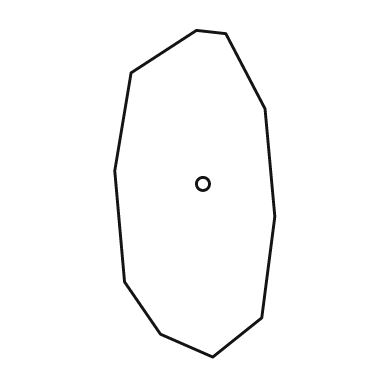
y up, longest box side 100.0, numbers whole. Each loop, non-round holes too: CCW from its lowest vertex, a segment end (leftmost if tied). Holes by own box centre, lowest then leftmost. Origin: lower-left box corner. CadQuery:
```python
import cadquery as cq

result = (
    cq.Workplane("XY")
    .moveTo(30.0, 0.0)
    .lineTo(45.0, 12.0)
    .lineTo(49.0, 43.0)
    .lineTo(46.0, 76.0)
    .lineTo(34.0, 99.0)
    .lineTo(25.0, 100.0)
    .lineTo(5.0, 87.0)
    .lineTo(0.0, 57.0)
    .lineTo(3.0, 23.0)
    .lineTo(14.0, 7.0)
    .close()
    .moveTo(27.0, 53.0)
    .circle(2.0)
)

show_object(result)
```